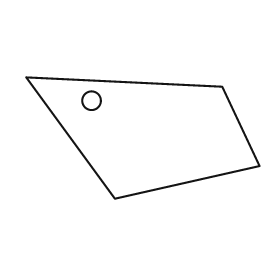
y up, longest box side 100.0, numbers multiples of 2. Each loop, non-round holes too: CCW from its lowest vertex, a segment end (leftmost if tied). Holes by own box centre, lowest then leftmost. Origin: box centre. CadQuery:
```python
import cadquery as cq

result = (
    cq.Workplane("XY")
    .moveTo(-12.0, -26.0)
    .lineTo(50.0, -12.0)
    .lineTo(34.0, 22.0)
    .lineTo(-50.0, 26.0)
    .close()
    .moveTo(-22.0, 16.0)
    .circle(4.0)
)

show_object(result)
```